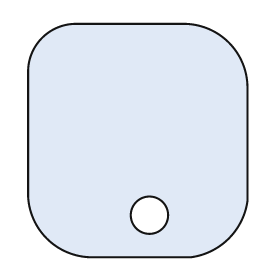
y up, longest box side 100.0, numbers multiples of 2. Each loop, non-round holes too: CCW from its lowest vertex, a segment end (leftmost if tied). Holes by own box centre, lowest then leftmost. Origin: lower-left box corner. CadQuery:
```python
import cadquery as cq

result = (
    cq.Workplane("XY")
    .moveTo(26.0, 0.0)
    .lineTo(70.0, 0.0)
    .threePointArc((86.0, 8.0), (94.0, 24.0))
    .lineTo(94.0, 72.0)
    .threePointArc((86.0, 92.0), (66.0, 100.0))
    .lineTo(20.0, 100.0)
    .threePointArc((6.0, 94.0), (0.0, 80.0))
    .lineTo(0.0, 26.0)
    .threePointArc((8.0, 8.0), (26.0, 0.0))
    .close()
    .moveTo(52.0, 18.0)
    .circle(8.0)
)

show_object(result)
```